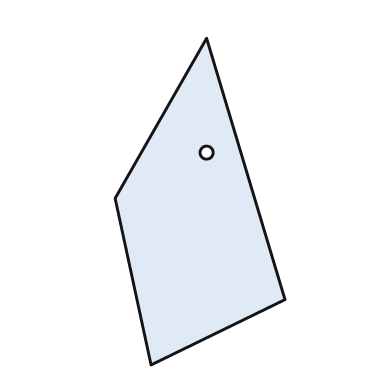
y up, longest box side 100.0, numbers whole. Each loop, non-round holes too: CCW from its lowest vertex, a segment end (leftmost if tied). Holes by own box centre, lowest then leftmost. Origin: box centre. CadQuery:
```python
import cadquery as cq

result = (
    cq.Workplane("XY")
    .moveTo(-15.0, -50.0)
    .lineTo(26.0, -30.0)
    .lineTo(2.0, 50.0)
    .lineTo(-26.0, 1.0)
    .close()
    .moveTo(2.0, 15.0)
    .circle(2.0)
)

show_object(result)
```